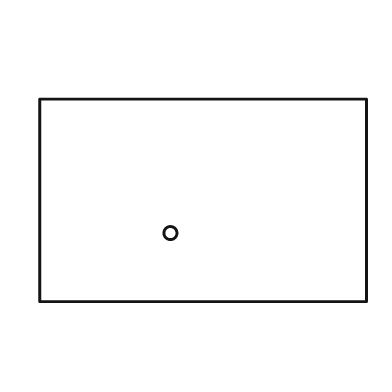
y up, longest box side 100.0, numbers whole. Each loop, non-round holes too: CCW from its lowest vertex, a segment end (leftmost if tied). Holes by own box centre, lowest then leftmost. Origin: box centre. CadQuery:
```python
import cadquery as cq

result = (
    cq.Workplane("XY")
    .moveTo(-50.0, -31.0)
    .lineTo(50.0, -31.0)
    .lineTo(50.0, 31.0)
    .lineTo(-50.0, 31.0)
    .close()
    .moveTo(-10.0, -10.0)
    .circle(2.0)
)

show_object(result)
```